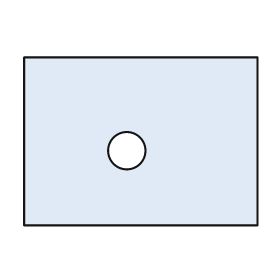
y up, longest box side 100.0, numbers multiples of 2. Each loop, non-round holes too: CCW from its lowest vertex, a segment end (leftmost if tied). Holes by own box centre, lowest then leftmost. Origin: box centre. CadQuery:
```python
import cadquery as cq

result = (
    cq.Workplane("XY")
    .moveTo(-50.0, -36.0)
    .lineTo(50.0, -36.0)
    .lineTo(50.0, 36.0)
    .lineTo(-50.0, 36.0)
    .close()
    .moveTo(-6.0, -4.0)
    .circle(8.0)
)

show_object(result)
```